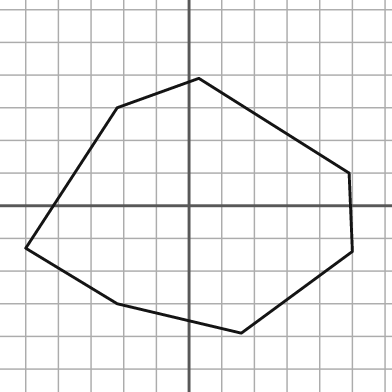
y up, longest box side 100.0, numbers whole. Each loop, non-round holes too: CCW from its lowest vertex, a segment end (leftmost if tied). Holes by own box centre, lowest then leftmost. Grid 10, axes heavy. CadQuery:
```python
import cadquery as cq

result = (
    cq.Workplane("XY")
    .moveTo(16.0, -39.0)
    .lineTo(50.0, -14.0)
    .lineTo(49.0, 10.0)
    .lineTo(3.0, 39.0)
    .lineTo(-22.0, 30.0)
    .lineTo(-50.0, -13.0)
    .lineTo(-22.0, -30.0)
    .close()
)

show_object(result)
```